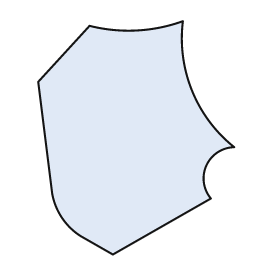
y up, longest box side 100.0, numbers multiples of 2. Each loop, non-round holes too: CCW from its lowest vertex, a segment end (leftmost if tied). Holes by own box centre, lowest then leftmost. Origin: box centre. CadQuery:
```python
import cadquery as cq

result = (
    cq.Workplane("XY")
    .moveTo(-10.0, -50.0)
    .lineTo(32.0, -26.0)
    .threePointArc((30.0, -12.0), (42.0, -4.0))
    .threePointArc((24.0, 20.0), (20.0, 50.0))
    .threePointArc((0.0, 46.0), (-20.0, 48.0))
    .lineTo(-42.0, 24.0)
    .lineTo(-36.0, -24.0)
    .threePointArc((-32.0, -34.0), (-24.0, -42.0))
    .close()
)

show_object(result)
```